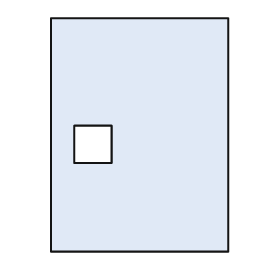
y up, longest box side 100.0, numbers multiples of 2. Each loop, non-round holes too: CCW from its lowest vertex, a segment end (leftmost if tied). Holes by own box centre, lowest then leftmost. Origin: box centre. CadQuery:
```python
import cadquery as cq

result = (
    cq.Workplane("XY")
    .moveTo(-38.0, -50.0)
    .lineTo(38.0, -50.0)
    .lineTo(38.0, 50.0)
    .lineTo(-38.0, 50.0)
    .close()
    .moveTo(-28.0, -12.0)
    .lineTo(-12.0, -12.0)
    .lineTo(-12.0, 4.0)
    .lineTo(-28.0, 4.0)
    .close()
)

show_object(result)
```